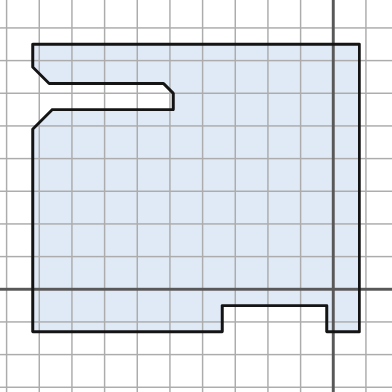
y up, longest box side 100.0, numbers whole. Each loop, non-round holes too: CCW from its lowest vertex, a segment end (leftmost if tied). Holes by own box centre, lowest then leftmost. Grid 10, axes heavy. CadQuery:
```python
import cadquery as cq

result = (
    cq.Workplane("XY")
    .moveTo(-92.0, -13.0)
    .lineTo(-34.0, -13.0)
    .lineTo(-34.0, -5.0)
    .lineTo(-2.0, -5.0)
    .lineTo(-2.0, -13.0)
    .lineTo(8.0, -13.0)
    .lineTo(8.0, 75.0)
    .lineTo(-92.0, 75.0)
    .lineTo(-92.0, 68.0)
    .lineTo(-87.0, 63.0)
    .lineTo(-52.0, 63.0)
    .lineTo(-49.0, 60.0)
    .lineTo(-49.0, 55.0)
    .lineTo(-86.0, 55.0)
    .lineTo(-92.0, 49.0)
    .close()
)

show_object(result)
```